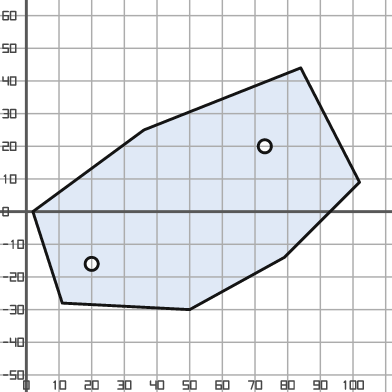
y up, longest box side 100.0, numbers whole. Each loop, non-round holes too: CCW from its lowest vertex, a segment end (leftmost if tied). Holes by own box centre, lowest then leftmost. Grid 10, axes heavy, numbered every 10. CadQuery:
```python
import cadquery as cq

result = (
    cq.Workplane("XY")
    .moveTo(50.0, -30.0)
    .lineTo(79.0, -14.0)
    .lineTo(102.0, 9.0)
    .lineTo(84.0, 44.0)
    .lineTo(36.0, 25.0)
    .lineTo(2.0, 0.0)
    .lineTo(11.0, -28.0)
    .close()
    .moveTo(20.0, -16.0)
    .circle(2.0)
    .moveTo(73.0, 20.0)
    .circle(2.0)
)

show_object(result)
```